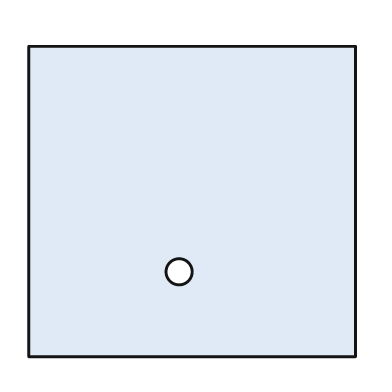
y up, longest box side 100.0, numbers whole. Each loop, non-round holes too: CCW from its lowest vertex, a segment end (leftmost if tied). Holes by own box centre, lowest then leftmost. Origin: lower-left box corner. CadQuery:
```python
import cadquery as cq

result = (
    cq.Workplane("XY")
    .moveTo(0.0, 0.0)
    .lineTo(100.0, 0.0)
    .lineTo(100.0, 95.0)
    .lineTo(0.0, 95.0)
    .close()
    .moveTo(46.0, 26.0)
    .circle(4.0)
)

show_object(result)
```